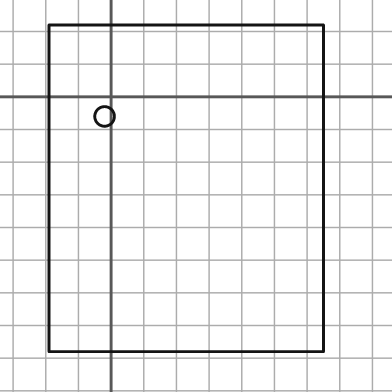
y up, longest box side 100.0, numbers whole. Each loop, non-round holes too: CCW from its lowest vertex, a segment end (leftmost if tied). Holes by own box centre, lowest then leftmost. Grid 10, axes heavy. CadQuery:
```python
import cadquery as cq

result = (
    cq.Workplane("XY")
    .moveTo(-19.0, -78.0)
    .lineTo(65.0, -78.0)
    .lineTo(65.0, 22.0)
    .lineTo(-19.0, 22.0)
    .close()
    .moveTo(-2.0, -6.0)
    .circle(3.0)
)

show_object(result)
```